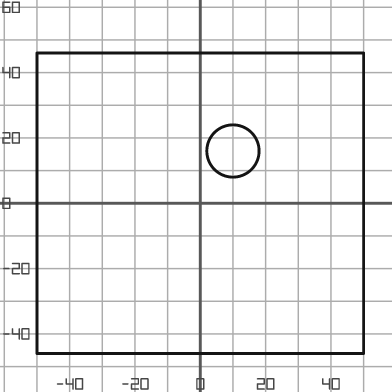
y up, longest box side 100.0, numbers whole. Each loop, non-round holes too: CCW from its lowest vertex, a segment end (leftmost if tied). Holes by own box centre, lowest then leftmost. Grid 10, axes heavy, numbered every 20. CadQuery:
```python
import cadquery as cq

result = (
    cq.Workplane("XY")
    .moveTo(-50.0, -46.0)
    .lineTo(50.0, -46.0)
    .lineTo(50.0, 46.0)
    .lineTo(-50.0, 46.0)
    .close()
    .moveTo(10.0, 16.0)
    .circle(8.0)
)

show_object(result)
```